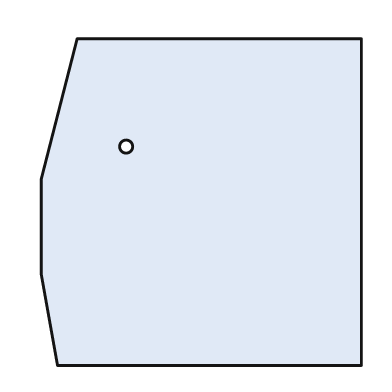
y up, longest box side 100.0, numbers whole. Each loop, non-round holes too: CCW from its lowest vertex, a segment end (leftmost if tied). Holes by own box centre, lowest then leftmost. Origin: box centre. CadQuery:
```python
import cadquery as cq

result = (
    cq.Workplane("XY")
    .moveTo(-44.0, -50.0)
    .lineTo(49.0, -50.0)
    .lineTo(49.0, 50.0)
    .lineTo(-38.0, 50.0)
    .lineTo(-49.0, 7.0)
    .lineTo(-49.0, -22.0)
    .close()
    .moveTo(-23.0, 17.0)
    .circle(2.0)
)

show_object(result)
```